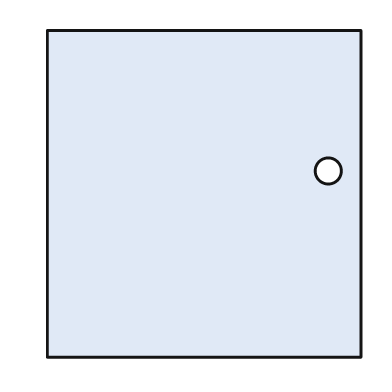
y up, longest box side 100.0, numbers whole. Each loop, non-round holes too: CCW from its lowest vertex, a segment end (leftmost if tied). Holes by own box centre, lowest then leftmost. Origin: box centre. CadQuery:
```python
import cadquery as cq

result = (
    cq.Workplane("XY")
    .moveTo(-48.0, -50.0)
    .lineTo(48.0, -50.0)
    .lineTo(48.0, 50.0)
    .lineTo(-48.0, 50.0)
    .close()
    .moveTo(38.0, 7.0)
    .circle(4.0)
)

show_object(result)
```